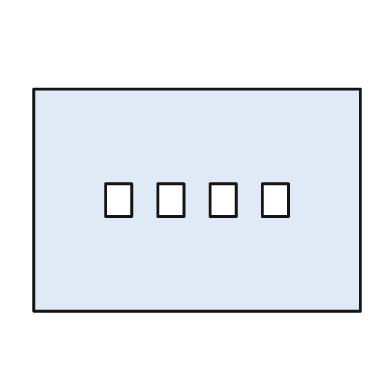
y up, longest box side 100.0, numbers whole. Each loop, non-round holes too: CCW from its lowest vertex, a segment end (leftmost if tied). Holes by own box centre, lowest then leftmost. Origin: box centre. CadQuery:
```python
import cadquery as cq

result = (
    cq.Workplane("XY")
    .moveTo(-50.0, -34.0)
    .lineTo(50.0, -34.0)
    .lineTo(50.0, 34.0)
    .lineTo(-50.0, 34.0)
    .close()
    .moveTo(-28.0, -5.0)
    .lineTo(-20.0, -5.0)
    .lineTo(-20.0, 5.0)
    .lineTo(-28.0, 5.0)
    .close()
    .moveTo(-12.0, -5.0)
    .lineTo(-4.0, -5.0)
    .lineTo(-4.0, 5.0)
    .lineTo(-12.0, 5.0)
    .close()
    .moveTo(4.0, -5.0)
    .lineTo(12.0, -5.0)
    .lineTo(12.0, 5.0)
    .lineTo(4.0, 5.0)
    .close()
    .moveTo(20.0, -5.0)
    .lineTo(28.0, -5.0)
    .lineTo(28.0, 5.0)
    .lineTo(20.0, 5.0)
    .close()
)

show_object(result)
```